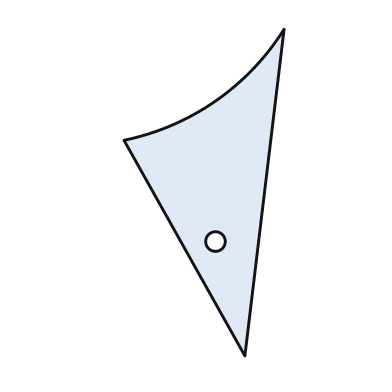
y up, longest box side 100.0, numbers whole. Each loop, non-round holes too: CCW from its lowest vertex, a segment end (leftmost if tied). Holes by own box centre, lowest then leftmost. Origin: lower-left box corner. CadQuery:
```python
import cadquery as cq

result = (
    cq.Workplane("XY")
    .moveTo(37.0, 0.0)
    .lineTo(49.0, 100.0)
    .threePointArc((28.0, 78.0), (0.0, 66.0))
    .close()
    .moveTo(28.0, 35.0)
    .circle(3.0)
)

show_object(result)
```